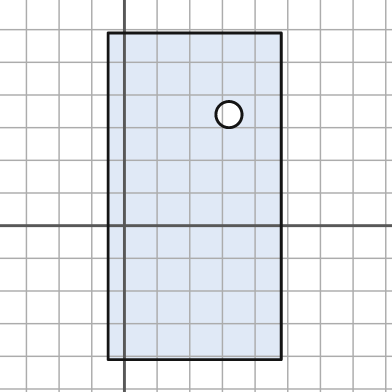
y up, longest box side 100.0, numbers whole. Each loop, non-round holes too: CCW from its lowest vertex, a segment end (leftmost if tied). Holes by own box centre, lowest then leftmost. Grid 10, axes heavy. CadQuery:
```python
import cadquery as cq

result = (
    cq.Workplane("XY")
    .moveTo(-5.0, -41.0)
    .lineTo(48.0, -41.0)
    .lineTo(48.0, 59.0)
    .lineTo(-5.0, 59.0)
    .close()
    .moveTo(32.0, 34.0)
    .circle(4.0)
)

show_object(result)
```